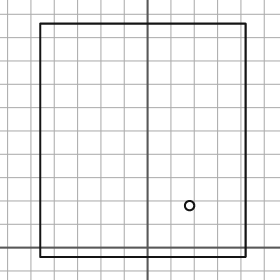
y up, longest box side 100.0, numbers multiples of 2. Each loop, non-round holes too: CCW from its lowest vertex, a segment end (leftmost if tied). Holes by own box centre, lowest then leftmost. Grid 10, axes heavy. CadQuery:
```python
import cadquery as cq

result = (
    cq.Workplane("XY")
    .moveTo(-46.0, -4.0)
    .lineTo(42.0, -4.0)
    .lineTo(42.0, 96.0)
    .lineTo(-46.0, 96.0)
    .close()
    .moveTo(18.0, 18.0)
    .circle(2.0)
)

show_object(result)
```